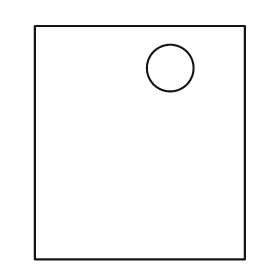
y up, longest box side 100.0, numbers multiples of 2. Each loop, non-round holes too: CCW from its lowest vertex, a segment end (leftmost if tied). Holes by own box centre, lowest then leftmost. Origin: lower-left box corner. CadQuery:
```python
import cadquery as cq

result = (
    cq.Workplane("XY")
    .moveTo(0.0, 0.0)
    .lineTo(90.0, 0.0)
    .lineTo(90.0, 100.0)
    .lineTo(0.0, 100.0)
    .close()
    .moveTo(58.0, 82.0)
    .circle(10.0)
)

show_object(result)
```